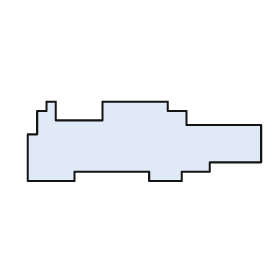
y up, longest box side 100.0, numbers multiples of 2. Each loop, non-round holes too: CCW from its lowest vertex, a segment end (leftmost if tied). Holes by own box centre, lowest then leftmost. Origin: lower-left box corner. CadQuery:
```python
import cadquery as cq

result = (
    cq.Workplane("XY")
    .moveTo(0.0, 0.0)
    .lineTo(20.0, 0.0)
    .lineTo(20.0, 4.0)
    .lineTo(52.0, 4.0)
    .lineTo(52.0, 0.0)
    .lineTo(66.0, 0.0)
    .lineTo(66.0, 4.0)
    .lineTo(78.0, 4.0)
    .lineTo(78.0, 8.0)
    .lineTo(100.0, 8.0)
    .lineTo(100.0, 24.0)
    .lineTo(68.0, 24.0)
    .lineTo(68.0, 30.0)
    .lineTo(60.0, 30.0)
    .lineTo(60.0, 34.0)
    .lineTo(32.0, 34.0)
    .lineTo(32.0, 26.0)
    .lineTo(12.0, 26.0)
    .lineTo(12.0, 34.0)
    .lineTo(8.0, 34.0)
    .lineTo(8.0, 30.0)
    .lineTo(4.0, 30.0)
    .lineTo(4.0, 20.0)
    .lineTo(0.0, 20.0)
    .close()
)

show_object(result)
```